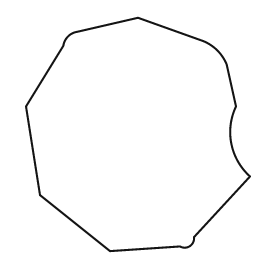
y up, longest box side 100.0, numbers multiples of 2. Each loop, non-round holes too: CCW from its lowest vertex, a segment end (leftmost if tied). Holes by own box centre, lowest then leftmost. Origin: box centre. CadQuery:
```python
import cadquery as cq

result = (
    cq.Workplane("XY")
    .moveTo(-12.0, -50.0)
    .lineTo(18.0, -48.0)
    .threePointArc((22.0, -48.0), (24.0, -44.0))
    .lineTo(48.0, -18.0)
    .threePointArc((40.0, -4.0), (42.0, 12.0))
    .lineTo(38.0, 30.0)
    .threePointArc((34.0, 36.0), (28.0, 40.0))
    .lineTo(0.0, 50.0)
    .lineTo(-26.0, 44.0)
    .threePointArc((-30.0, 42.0), (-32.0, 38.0))
    .lineTo(-48.0, 12.0)
    .lineTo(-42.0, -26.0)
    .close()
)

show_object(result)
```